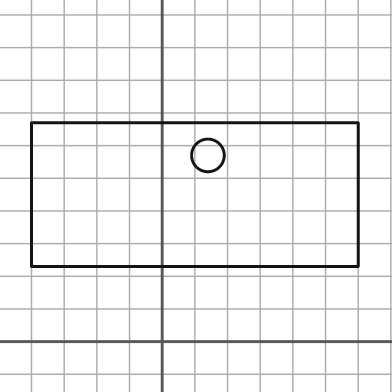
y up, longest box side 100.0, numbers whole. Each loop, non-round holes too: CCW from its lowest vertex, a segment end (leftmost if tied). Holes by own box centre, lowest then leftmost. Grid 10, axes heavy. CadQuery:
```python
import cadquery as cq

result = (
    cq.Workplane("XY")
    .moveTo(-40.0, 23.0)
    .lineTo(60.0, 23.0)
    .lineTo(60.0, 67.0)
    .lineTo(-40.0, 67.0)
    .close()
    .moveTo(14.0, 57.0)
    .circle(5.0)
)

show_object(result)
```